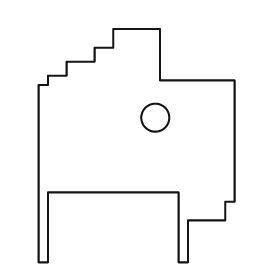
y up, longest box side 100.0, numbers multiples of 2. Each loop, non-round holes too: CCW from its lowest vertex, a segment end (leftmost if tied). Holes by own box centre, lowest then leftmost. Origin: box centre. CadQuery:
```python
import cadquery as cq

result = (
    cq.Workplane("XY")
    .moveTo(-42.0, -50.0)
    .lineTo(-38.0, -50.0)
    .lineTo(-38.0, -20.0)
    .lineTo(18.0, -20.0)
    .lineTo(18.0, -50.0)
    .lineTo(22.0, -50.0)
    .lineTo(22.0, -32.0)
    .lineTo(38.0, -32.0)
    .lineTo(38.0, -24.0)
    .lineTo(42.0, -24.0)
    .lineTo(42.0, 28.0)
    .lineTo(10.0, 28.0)
    .lineTo(10.0, 50.0)
    .lineTo(-10.0, 50.0)
    .lineTo(-10.0, 42.0)
    .lineTo(-18.0, 42.0)
    .lineTo(-18.0, 36.0)
    .lineTo(-30.0, 36.0)
    .lineTo(-30.0, 30.0)
    .lineTo(-38.0, 30.0)
    .lineTo(-38.0, 26.0)
    .lineTo(-42.0, 26.0)
    .close()
    .moveTo(8.0, 12.0)
    .circle(6.0)
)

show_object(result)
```